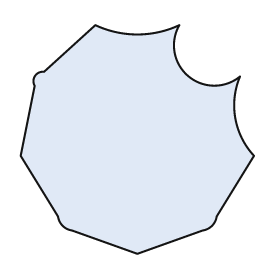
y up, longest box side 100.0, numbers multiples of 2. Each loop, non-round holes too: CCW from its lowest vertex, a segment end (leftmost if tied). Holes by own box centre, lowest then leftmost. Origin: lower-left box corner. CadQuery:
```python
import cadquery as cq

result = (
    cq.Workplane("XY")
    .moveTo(50.0, 0.0)
    .lineTo(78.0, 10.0)
    .threePointArc((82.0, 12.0), (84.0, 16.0))
    .lineTo(100.0, 42.0)
    .threePointArc((92.0, 58.0), (94.0, 76.0))
    .threePointArc((72.0, 76.0), (68.0, 98.0))
    .threePointArc((50.0, 94.0), (32.0, 98.0))
    .lineTo(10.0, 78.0)
    .threePointArc((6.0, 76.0), (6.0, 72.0))
    .lineTo(0.0, 42.0)
    .lineTo(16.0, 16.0)
    .threePointArc((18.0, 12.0), (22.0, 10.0))
    .close()
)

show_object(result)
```